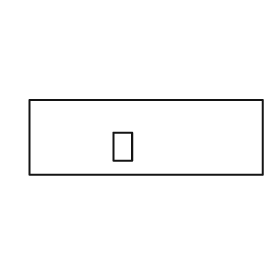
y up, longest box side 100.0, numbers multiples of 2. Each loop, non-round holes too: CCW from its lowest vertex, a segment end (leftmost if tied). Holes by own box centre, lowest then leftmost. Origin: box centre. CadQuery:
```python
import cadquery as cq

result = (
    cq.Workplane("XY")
    .moveTo(-50.0, -16.0)
    .lineTo(50.0, -16.0)
    .lineTo(50.0, 16.0)
    .lineTo(-50.0, 16.0)
    .close()
    .moveTo(-14.0, -10.0)
    .lineTo(-6.0, -10.0)
    .lineTo(-6.0, 2.0)
    .lineTo(-14.0, 2.0)
    .close()
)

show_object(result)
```